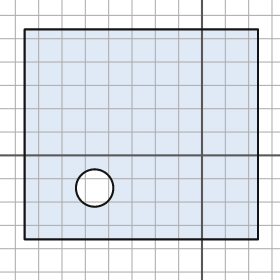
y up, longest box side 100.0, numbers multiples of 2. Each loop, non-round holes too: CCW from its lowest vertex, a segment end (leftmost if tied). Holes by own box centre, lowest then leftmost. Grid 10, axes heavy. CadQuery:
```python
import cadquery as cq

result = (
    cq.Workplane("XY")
    .moveTo(-76.0, -36.0)
    .lineTo(24.0, -36.0)
    .lineTo(24.0, 54.0)
    .lineTo(-76.0, 54.0)
    .close()
    .moveTo(-46.0, -14.0)
    .circle(8.0)
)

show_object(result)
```